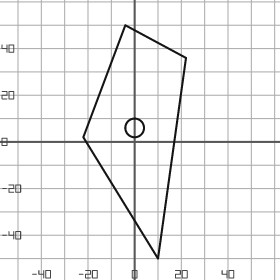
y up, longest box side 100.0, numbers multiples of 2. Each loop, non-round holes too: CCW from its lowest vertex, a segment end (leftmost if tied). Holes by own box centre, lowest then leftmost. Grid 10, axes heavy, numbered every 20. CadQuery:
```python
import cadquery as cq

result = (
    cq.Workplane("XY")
    .moveTo(10.0, -50.0)
    .lineTo(22.0, 36.0)
    .lineTo(-4.0, 50.0)
    .lineTo(-22.0, 2.0)
    .close()
    .moveTo(0.0, 6.0)
    .circle(4.0)
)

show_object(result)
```